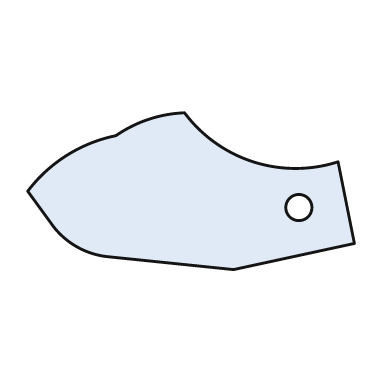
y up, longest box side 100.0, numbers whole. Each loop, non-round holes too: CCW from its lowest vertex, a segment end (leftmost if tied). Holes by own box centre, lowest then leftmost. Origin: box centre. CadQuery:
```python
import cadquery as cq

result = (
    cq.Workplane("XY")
    .moveTo(13.0, -24.0)
    .lineTo(50.0, -16.0)
    .lineTo(45.0, 9.0)
    .threePointArc((19.0, 9.0), (-2.0, 24.0))
    .threePointArc((-13.0, 22.0), (-23.0, 17.0))
    .threePointArc((-38.0, 11.0), (-50.0, 0.0))
    .lineTo(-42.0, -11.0)
    .threePointArc((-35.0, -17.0), (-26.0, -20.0))
    .close()
    .moveTo(33.0, -5.0)
    .circle(4.0)
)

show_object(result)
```